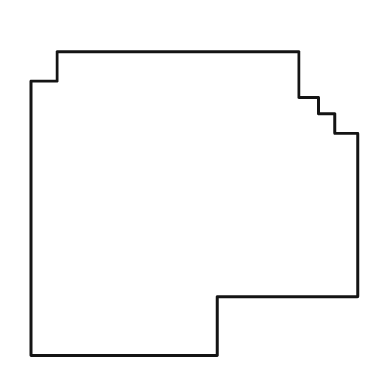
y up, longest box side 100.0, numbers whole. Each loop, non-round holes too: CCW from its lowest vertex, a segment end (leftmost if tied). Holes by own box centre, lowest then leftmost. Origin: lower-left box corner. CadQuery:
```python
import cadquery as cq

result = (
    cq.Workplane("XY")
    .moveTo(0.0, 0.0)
    .lineTo(57.0, 0.0)
    .lineTo(57.0, 18.0)
    .lineTo(100.0, 18.0)
    .lineTo(100.0, 68.0)
    .lineTo(93.0, 68.0)
    .lineTo(93.0, 74.0)
    .lineTo(88.0, 74.0)
    .lineTo(88.0, 79.0)
    .lineTo(82.0, 79.0)
    .lineTo(82.0, 93.0)
    .lineTo(8.0, 93.0)
    .lineTo(8.0, 84.0)
    .lineTo(0.0, 84.0)
    .close()
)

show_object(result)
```